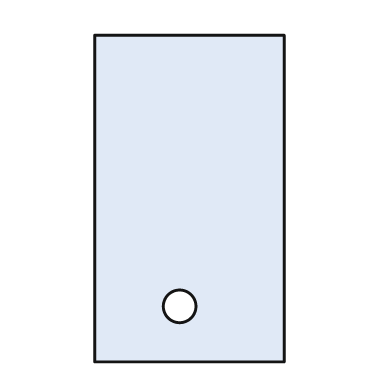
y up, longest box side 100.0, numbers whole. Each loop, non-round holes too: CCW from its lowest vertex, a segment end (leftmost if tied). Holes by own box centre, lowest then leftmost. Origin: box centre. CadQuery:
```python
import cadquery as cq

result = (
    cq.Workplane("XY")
    .moveTo(-29.0, -50.0)
    .lineTo(29.0, -50.0)
    .lineTo(29.0, 50.0)
    .lineTo(-29.0, 50.0)
    .close()
    .moveTo(-3.0, -33.0)
    .circle(5.0)
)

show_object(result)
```